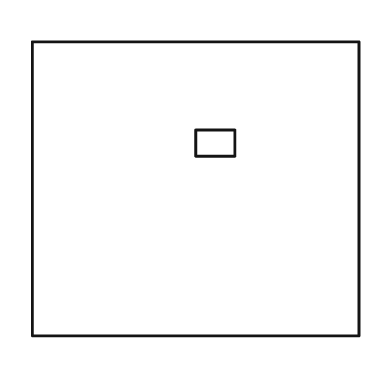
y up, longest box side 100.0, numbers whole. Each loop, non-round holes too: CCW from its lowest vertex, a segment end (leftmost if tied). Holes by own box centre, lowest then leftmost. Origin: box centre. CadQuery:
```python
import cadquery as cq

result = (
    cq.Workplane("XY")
    .moveTo(-50.0, -45.0)
    .lineTo(50.0, -45.0)
    .lineTo(50.0, 45.0)
    .lineTo(-50.0, 45.0)
    .close()
    .moveTo(0.0, 10.0)
    .lineTo(12.0, 10.0)
    .lineTo(12.0, 18.0)
    .lineTo(0.0, 18.0)
    .close()
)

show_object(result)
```